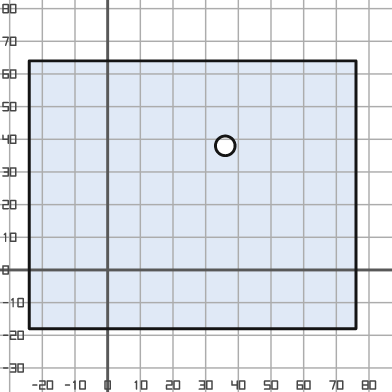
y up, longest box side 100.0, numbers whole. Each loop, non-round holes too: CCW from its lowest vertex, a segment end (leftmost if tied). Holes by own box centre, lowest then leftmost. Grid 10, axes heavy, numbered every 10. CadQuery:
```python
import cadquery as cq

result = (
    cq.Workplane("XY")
    .moveTo(-24.0, -18.0)
    .lineTo(76.0, -18.0)
    .lineTo(76.0, 64.0)
    .lineTo(-24.0, 64.0)
    .close()
    .moveTo(36.0, 38.0)
    .circle(3.0)
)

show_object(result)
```